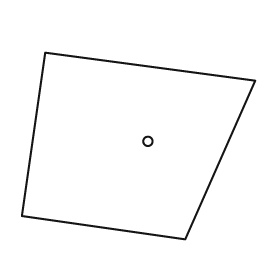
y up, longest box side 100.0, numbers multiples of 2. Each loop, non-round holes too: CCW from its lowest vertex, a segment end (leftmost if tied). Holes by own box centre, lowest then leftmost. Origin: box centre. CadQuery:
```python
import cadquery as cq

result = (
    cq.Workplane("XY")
    .moveTo(20.0, -40.0)
    .lineTo(50.0, 28.0)
    .lineTo(-40.0, 40.0)
    .lineTo(-50.0, -30.0)
    .close()
    .moveTo(4.0, 2.0)
    .circle(2.0)
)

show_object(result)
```